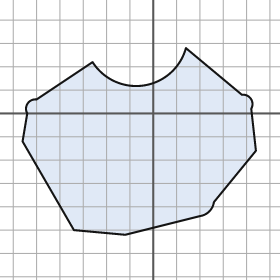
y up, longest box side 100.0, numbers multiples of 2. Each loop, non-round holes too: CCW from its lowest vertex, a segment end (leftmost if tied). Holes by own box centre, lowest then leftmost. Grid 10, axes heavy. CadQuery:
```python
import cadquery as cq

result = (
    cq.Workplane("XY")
    .moveTo(-12.0, -52.0)
    .lineTo(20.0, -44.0)
    .threePointArc((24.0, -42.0), (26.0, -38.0))
    .lineTo(44.0, -16.0)
    .lineTo(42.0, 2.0)
    .threePointArc((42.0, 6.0), (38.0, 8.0))
    .lineTo(14.0, 28.0)
    .threePointArc((-4.0, 12.0), (-26.0, 22.0))
    .lineTo(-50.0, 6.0)
    .threePointArc((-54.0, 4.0), (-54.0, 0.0))
    .lineTo(-56.0, -12.0)
    .lineTo(-34.0, -50.0)
    .close()
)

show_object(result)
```